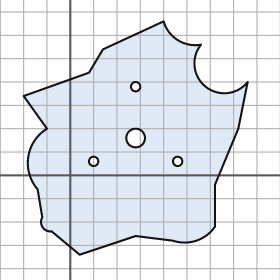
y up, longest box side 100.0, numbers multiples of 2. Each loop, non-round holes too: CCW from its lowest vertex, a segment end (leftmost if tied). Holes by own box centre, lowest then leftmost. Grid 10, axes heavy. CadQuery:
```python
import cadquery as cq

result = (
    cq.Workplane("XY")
    .moveTo(4.0, -34.0)
    .lineTo(28.0, -26.0)
    .lineTo(44.0, -28.0)
    .threePointArc((54.0, -28.0), (62.0, -22.0))
    .lineTo(62.0, -4.0)
    .lineTo(72.0, 20.0)
    .lineTo(76.0, 40.0)
    .threePointArc((58.0, 38.0), (56.0, 56.0))
    .threePointArc((46.0, 58.0), (40.0, 66.0))
    .lineTo(14.0, 54.0)
    .lineTo(8.0, 44.0)
    .lineTo(-20.0, 34.0)
    .lineTo(-10.0, 20.0)
    .threePointArc((-18.0, 8.0), (-14.0, -6.0))
    .lineTo(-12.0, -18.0)
    .threePointArc((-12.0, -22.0), (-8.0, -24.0))
    .close()
    .moveTo(10.0, 6.0)
    .circle(2.0)
    .moveTo(46.0, 6.0)
    .circle(2.0)
    .moveTo(28.0, 16.0)
    .circle(4.0)
    .moveTo(28.0, 38.0)
    .circle(2.0)
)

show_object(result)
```